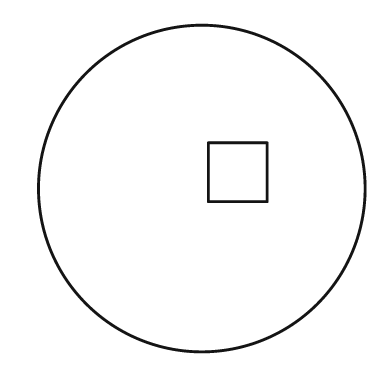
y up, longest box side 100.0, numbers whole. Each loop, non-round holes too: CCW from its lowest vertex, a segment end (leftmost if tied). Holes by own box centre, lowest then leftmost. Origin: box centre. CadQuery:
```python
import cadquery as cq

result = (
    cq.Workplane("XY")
    .moveTo(0.0, 0.0)
    .circle(50.0)
    .moveTo(2.0, -4.0)
    .lineTo(20.0, -4.0)
    .lineTo(20.0, 14.0)
    .lineTo(2.0, 14.0)
    .close()
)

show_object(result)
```